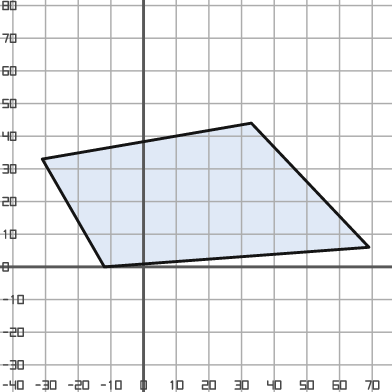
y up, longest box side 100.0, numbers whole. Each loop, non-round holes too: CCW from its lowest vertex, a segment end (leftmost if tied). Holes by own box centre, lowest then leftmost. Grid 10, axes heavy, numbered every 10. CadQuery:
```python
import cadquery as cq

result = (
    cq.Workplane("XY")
    .moveTo(-12.0, 0.0)
    .lineTo(69.0, 6.0)
    .lineTo(33.0, 44.0)
    .lineTo(-31.0, 33.0)
    .close()
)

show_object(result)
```